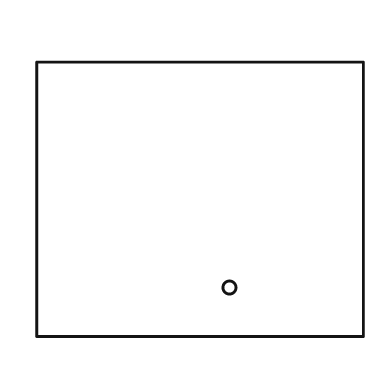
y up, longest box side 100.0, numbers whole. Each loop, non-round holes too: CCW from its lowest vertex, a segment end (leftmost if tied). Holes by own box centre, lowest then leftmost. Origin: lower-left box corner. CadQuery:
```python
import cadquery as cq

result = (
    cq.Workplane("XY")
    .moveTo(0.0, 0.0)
    .lineTo(100.0, 0.0)
    .lineTo(100.0, 84.0)
    .lineTo(0.0, 84.0)
    .close()
    .moveTo(59.0, 15.0)
    .circle(2.0)
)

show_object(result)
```